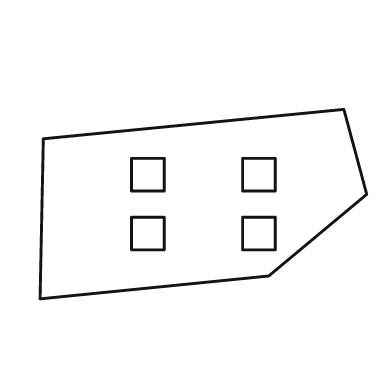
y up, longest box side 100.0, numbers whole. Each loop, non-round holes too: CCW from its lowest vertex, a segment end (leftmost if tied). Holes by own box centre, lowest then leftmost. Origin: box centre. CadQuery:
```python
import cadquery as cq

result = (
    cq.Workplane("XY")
    .moveTo(-50.0, -29.0)
    .lineTo(20.0, -22.0)
    .lineTo(50.0, 3.0)
    .lineTo(43.0, 29.0)
    .lineTo(-49.0, 20.0)
    .close()
    .moveTo(-22.0, -14.0)
    .lineTo(-12.0, -14.0)
    .lineTo(-12.0, -4.0)
    .lineTo(-22.0, -4.0)
    .close()
    .moveTo(12.0, -14.0)
    .lineTo(22.0, -14.0)
    .lineTo(22.0, -4.0)
    .lineTo(12.0, -4.0)
    .close()
    .moveTo(-22.0, 4.0)
    .lineTo(-12.0, 4.0)
    .lineTo(-12.0, 14.0)
    .lineTo(-22.0, 14.0)
    .close()
    .moveTo(12.0, 4.0)
    .lineTo(22.0, 4.0)
    .lineTo(22.0, 14.0)
    .lineTo(12.0, 14.0)
    .close()
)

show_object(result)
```